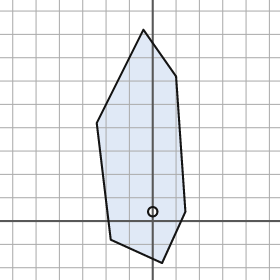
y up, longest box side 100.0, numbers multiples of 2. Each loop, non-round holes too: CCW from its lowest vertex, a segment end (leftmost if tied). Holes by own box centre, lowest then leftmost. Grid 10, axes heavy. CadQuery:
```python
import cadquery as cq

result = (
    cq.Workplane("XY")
    .moveTo(4.0, -18.0)
    .lineTo(14.0, 4.0)
    .lineTo(10.0, 62.0)
    .lineTo(-4.0, 82.0)
    .lineTo(-24.0, 42.0)
    .lineTo(-18.0, -8.0)
    .close()
    .moveTo(0.0, 4.0)
    .circle(2.0)
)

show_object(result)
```